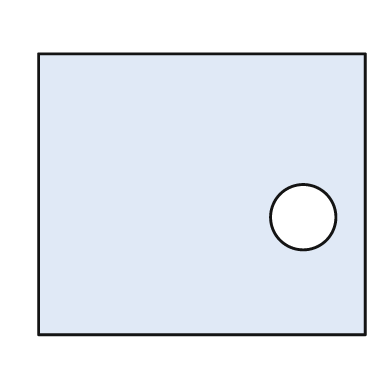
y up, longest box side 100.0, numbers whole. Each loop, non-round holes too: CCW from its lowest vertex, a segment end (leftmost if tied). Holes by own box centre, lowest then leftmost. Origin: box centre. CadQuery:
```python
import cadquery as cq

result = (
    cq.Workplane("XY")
    .moveTo(-50.0, -43.0)
    .lineTo(50.0, -43.0)
    .lineTo(50.0, 43.0)
    .lineTo(-50.0, 43.0)
    .close()
    .moveTo(31.0, -7.0)
    .circle(10.0)
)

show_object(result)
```